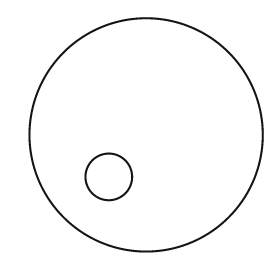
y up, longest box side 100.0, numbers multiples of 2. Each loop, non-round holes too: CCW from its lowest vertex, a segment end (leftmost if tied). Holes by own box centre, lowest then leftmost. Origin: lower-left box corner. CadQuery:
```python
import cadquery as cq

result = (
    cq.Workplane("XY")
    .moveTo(50.0, 50.0)
    .circle(50.0)
    .moveTo(34.0, 32.0)
    .circle(10.0)
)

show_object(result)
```